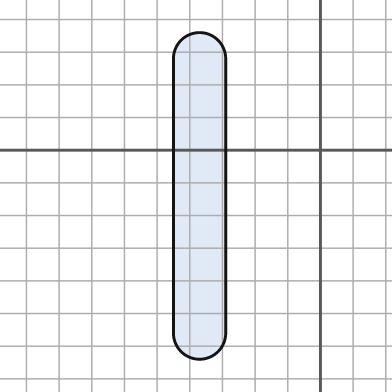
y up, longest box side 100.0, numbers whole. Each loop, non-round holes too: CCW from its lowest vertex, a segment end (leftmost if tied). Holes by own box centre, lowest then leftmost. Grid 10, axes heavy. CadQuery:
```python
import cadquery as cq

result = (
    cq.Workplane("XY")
    .moveTo(-45.0, -56.0)
    .threePointArc((-37.0, -64.0), (-29.0, -56.0))
    .lineTo(-29.0, 28.0)
    .threePointArc((-37.0, 36.0), (-45.0, 28.0))
    .close()
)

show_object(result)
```